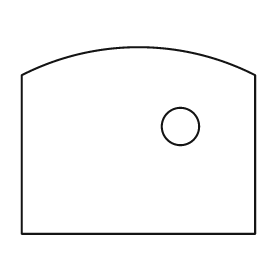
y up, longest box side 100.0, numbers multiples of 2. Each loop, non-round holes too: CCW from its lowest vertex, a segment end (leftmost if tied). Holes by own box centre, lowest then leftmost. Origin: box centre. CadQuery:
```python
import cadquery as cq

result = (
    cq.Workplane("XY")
    .moveTo(-50.0, -40.0)
    .lineTo(50.0, -40.0)
    .lineTo(50.0, 28.0)
    .threePointArc((0.0, 40.0), (-50.0, 28.0))
    .close()
    .moveTo(18.0, 6.0)
    .circle(8.0)
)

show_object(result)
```